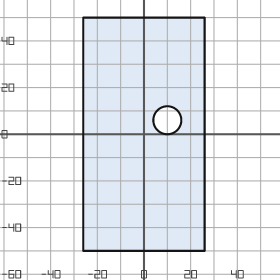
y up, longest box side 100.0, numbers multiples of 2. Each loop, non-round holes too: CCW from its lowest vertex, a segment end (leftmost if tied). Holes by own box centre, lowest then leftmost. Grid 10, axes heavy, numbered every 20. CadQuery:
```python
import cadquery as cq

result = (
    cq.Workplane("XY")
    .moveTo(-26.0, -50.0)
    .lineTo(26.0, -50.0)
    .lineTo(26.0, 50.0)
    .lineTo(-26.0, 50.0)
    .close()
    .moveTo(10.0, 6.0)
    .circle(6.0)
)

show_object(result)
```